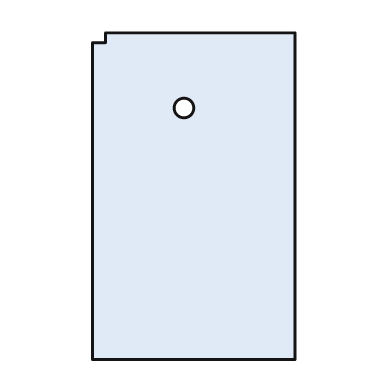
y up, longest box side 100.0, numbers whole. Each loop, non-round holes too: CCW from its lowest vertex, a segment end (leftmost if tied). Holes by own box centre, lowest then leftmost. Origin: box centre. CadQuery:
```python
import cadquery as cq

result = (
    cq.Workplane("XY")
    .moveTo(-31.0, -50.0)
    .lineTo(31.0, -50.0)
    .lineTo(31.0, 50.0)
    .lineTo(-27.0, 50.0)
    .lineTo(-27.0, 47.0)
    .lineTo(-31.0, 47.0)
    .close()
    .moveTo(-3.0, 27.0)
    .circle(3.0)
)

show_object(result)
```